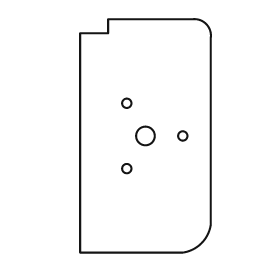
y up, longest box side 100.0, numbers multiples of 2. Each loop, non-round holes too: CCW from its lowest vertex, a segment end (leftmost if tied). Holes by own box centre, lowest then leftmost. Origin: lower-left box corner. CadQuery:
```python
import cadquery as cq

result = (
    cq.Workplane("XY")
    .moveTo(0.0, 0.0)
    .lineTo(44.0, 0.0)
    .threePointArc((52.0, 4.0), (56.0, 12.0))
    .lineTo(56.0, 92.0)
    .threePointArc((54.0, 98.0), (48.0, 100.0))
    .lineTo(12.0, 100.0)
    .lineTo(12.0, 94.0)
    .lineTo(0.0, 94.0)
    .close()
    .moveTo(20.0, 36.0)
    .circle(2.0)
    .moveTo(28.0, 50.0)
    .circle(4.0)
    .moveTo(44.0, 50.0)
    .circle(2.0)
    .moveTo(20.0, 64.0)
    .circle(2.0)
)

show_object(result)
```